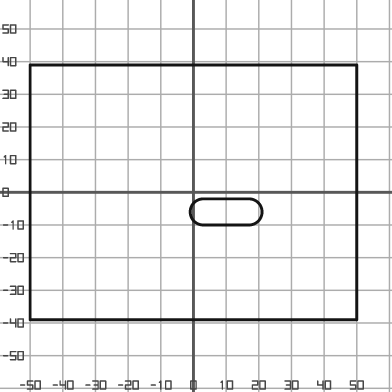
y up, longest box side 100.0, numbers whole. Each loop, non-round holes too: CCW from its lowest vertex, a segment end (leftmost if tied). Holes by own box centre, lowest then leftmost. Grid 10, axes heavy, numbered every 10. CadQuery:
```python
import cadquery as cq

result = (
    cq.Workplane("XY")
    .moveTo(-50.0, -39.0)
    .lineTo(50.0, -39.0)
    .lineTo(50.0, 39.0)
    .lineTo(-50.0, 39.0)
    .close()
    .moveTo(3.0, -10.0)
    .lineTo(17.0, -10.0)
    .threePointArc((21.0, -6.0), (17.0, -2.0))
    .lineTo(3.0, -2.0)
    .threePointArc((-1.0, -6.0), (3.0, -10.0))
    .close()
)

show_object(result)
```